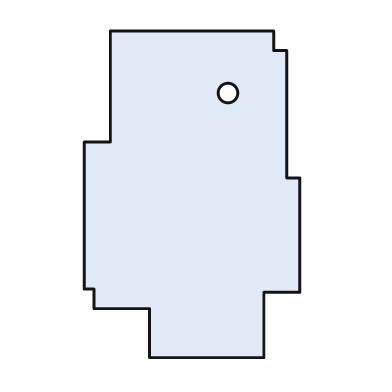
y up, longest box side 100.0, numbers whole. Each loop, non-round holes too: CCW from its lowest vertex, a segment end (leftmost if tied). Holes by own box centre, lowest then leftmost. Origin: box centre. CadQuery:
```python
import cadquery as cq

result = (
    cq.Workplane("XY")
    .moveTo(-13.0, -50.0)
    .lineTo(22.0, -50.0)
    .lineTo(22.0, -30.0)
    .lineTo(33.0, -30.0)
    .lineTo(33.0, 5.0)
    .lineTo(29.0, 5.0)
    .lineTo(29.0, 44.0)
    .lineTo(25.0, 44.0)
    .lineTo(25.0, 50.0)
    .lineTo(-25.0, 50.0)
    .lineTo(-25.0, 16.0)
    .lineTo(-33.0, 16.0)
    .lineTo(-33.0, -29.0)
    .lineTo(-30.0, -29.0)
    .lineTo(-30.0, -35.0)
    .lineTo(-13.0, -35.0)
    .close()
    .moveTo(11.0, 31.0)
    .circle(3.0)
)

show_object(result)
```